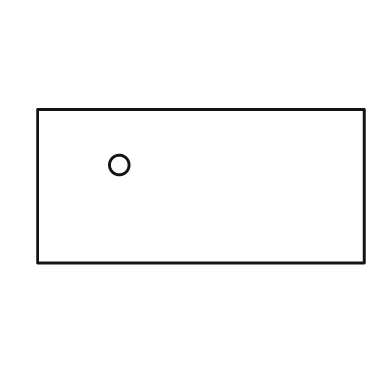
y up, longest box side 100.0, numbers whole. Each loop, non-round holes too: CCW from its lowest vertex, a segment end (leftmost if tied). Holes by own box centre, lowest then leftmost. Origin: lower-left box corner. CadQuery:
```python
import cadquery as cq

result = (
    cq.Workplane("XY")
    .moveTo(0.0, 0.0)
    .lineTo(100.0, 0.0)
    .lineTo(100.0, 47.0)
    .lineTo(0.0, 47.0)
    .close()
    .moveTo(25.0, 30.0)
    .circle(3.0)
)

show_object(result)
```